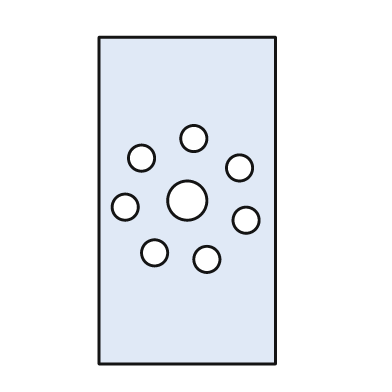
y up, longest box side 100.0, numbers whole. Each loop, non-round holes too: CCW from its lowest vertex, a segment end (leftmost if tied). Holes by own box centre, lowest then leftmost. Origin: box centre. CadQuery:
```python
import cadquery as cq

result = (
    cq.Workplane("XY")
    .moveTo(-27.0, -50.0)
    .lineTo(27.0, -50.0)
    .lineTo(27.0, 50.0)
    .lineTo(-27.0, 50.0)
    .close()
    .moveTo(6.0, -18.0)
    .circle(4.0)
    .moveTo(-10.0, -16.0)
    .circle(4.0)
    .moveTo(18.0, -6.0)
    .circle(4.0)
    .moveTo(-19.0, -2.0)
    .circle(4.0)
    .moveTo(0.0, 0.0)
    .circle(6.0)
    .moveTo(16.0, 10.0)
    .circle(4.0)
    .moveTo(-14.0, 13.0)
    .circle(4.0)
    .moveTo(2.0, 19.0)
    .circle(4.0)
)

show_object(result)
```